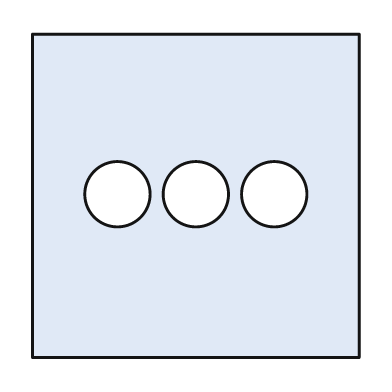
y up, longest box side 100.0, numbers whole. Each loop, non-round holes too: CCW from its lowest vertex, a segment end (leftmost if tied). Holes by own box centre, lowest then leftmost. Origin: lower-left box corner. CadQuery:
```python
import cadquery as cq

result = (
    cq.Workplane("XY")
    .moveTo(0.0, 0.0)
    .lineTo(100.0, 0.0)
    .lineTo(100.0, 99.0)
    .lineTo(0.0, 99.0)
    .close()
    .moveTo(26.0, 50.0)
    .circle(10.0)
    .moveTo(50.0, 50.0)
    .circle(10.0)
    .moveTo(74.0, 50.0)
    .circle(10.0)
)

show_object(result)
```